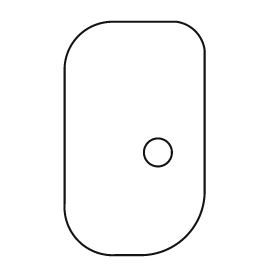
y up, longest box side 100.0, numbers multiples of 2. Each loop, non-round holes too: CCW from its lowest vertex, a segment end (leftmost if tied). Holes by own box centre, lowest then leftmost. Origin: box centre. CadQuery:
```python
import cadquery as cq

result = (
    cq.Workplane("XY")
    .moveTo(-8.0, -50.0)
    .lineTo(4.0, -50.0)
    .threePointArc((22.0, -42.0), (30.0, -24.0))
    .lineTo(30.0, 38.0)
    .threePointArc((26.0, 46.0), (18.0, 50.0))
    .lineTo(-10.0, 50.0)
    .threePointArc((-24.0, 44.0), (-30.0, 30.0))
    .lineTo(-30.0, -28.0)
    .threePointArc((-24.0, -44.0), (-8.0, -50.0))
    .close()
    .moveTo(10.0, -6.0)
    .circle(6.0)
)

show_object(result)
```